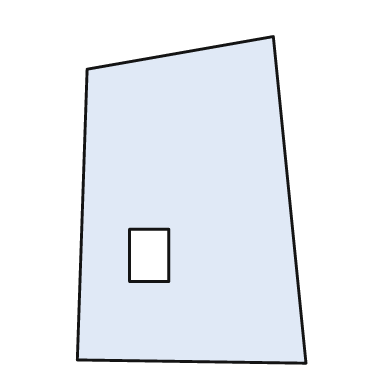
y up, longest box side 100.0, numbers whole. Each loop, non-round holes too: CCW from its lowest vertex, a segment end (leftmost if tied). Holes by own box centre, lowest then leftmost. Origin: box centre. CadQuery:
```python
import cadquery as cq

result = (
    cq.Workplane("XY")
    .moveTo(35.0, -50.0)
    .lineTo(25.0, 50.0)
    .lineTo(-32.0, 40.0)
    .lineTo(-35.0, -49.0)
    .close()
    .moveTo(-19.0, -25.0)
    .lineTo(-7.0, -25.0)
    .lineTo(-7.0, -9.0)
    .lineTo(-19.0, -9.0)
    .close()
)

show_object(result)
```